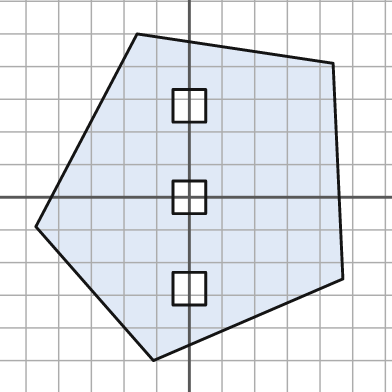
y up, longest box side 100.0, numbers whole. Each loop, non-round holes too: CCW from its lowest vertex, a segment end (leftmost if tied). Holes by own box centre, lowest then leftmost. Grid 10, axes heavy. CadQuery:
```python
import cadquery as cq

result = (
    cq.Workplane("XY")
    .moveTo(-11.0, -50.0)
    .lineTo(47.0, -25.0)
    .lineTo(44.0, 41.0)
    .lineTo(-16.0, 50.0)
    .lineTo(-47.0, -9.0)
    .close()
    .moveTo(-5.0, -33.0)
    .lineTo(5.0, -33.0)
    .lineTo(5.0, -23.0)
    .lineTo(-5.0, -23.0)
    .close()
    .moveTo(-5.0, -5.0)
    .lineTo(5.0, -5.0)
    .lineTo(5.0, 5.0)
    .lineTo(-5.0, 5.0)
    .close()
    .moveTo(-5.0, 23.0)
    .lineTo(5.0, 23.0)
    .lineTo(5.0, 33.0)
    .lineTo(-5.0, 33.0)
    .close()
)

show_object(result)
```